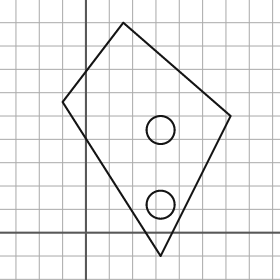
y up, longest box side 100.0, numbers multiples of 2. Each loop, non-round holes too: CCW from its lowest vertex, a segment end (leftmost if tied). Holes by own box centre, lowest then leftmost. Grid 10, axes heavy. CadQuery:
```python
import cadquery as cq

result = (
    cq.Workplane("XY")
    .moveTo(32.0, -10.0)
    .lineTo(62.0, 50.0)
    .lineTo(16.0, 90.0)
    .lineTo(-10.0, 56.0)
    .close()
    .moveTo(32.0, 12.0)
    .circle(6.0)
    .moveTo(32.0, 44.0)
    .circle(6.0)
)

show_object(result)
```